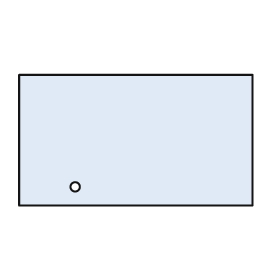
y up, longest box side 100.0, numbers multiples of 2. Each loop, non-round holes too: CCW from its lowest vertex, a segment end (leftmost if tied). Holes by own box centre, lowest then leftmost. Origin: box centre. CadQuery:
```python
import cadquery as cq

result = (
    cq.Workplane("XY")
    .moveTo(-50.0, -28.0)
    .lineTo(50.0, -28.0)
    .lineTo(50.0, 28.0)
    .lineTo(-50.0, 28.0)
    .close()
    .moveTo(-26.0, -20.0)
    .circle(2.0)
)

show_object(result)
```